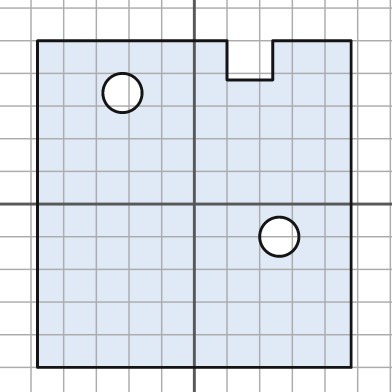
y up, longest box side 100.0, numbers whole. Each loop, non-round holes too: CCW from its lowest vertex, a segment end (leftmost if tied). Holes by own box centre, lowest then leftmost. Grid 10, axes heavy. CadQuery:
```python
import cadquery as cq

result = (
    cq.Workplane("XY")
    .moveTo(-48.0, -50.0)
    .lineTo(48.0, -50.0)
    .lineTo(48.0, 50.0)
    .lineTo(24.0, 50.0)
    .lineTo(24.0, 38.0)
    .lineTo(10.0, 38.0)
    .lineTo(10.0, 50.0)
    .lineTo(-48.0, 50.0)
    .close()
    .moveTo(26.0, -10.0)
    .circle(6.0)
    .moveTo(-22.0, 34.0)
    .circle(6.0)
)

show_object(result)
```